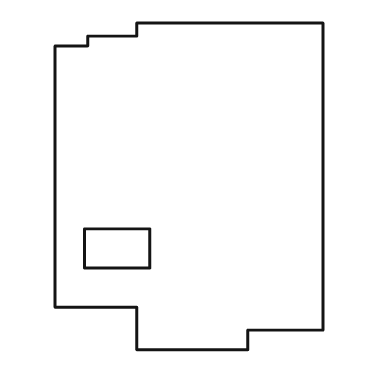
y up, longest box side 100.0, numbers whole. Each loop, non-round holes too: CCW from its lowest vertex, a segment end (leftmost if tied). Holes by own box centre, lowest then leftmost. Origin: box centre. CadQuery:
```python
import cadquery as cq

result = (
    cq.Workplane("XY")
    .moveTo(-16.0, -50.0)
    .lineTo(18.0, -50.0)
    .lineTo(18.0, -44.0)
    .lineTo(41.0, -44.0)
    .lineTo(41.0, 50.0)
    .lineTo(-16.0, 50.0)
    .lineTo(-16.0, 46.0)
    .lineTo(-31.0, 46.0)
    .lineTo(-31.0, 43.0)
    .lineTo(-41.0, 43.0)
    .lineTo(-41.0, -37.0)
    .lineTo(-16.0, -37.0)
    .close()
    .moveTo(-32.0, -25.0)
    .lineTo(-12.0, -25.0)
    .lineTo(-12.0, -13.0)
    .lineTo(-32.0, -13.0)
    .close()
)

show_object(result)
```